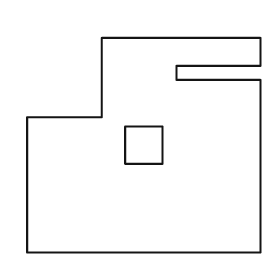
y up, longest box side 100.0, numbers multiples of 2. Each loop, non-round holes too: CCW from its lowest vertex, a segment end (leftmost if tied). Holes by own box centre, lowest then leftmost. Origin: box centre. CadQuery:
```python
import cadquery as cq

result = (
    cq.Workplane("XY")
    .moveTo(-50.0, -46.0)
    .lineTo(50.0, -46.0)
    .lineTo(50.0, 28.0)
    .lineTo(14.0, 28.0)
    .lineTo(14.0, 34.0)
    .lineTo(50.0, 34.0)
    .lineTo(50.0, 46.0)
    .lineTo(-18.0, 46.0)
    .lineTo(-18.0, 12.0)
    .lineTo(-50.0, 12.0)
    .close()
    .moveTo(-8.0, -8.0)
    .lineTo(8.0, -8.0)
    .lineTo(8.0, 8.0)
    .lineTo(-8.0, 8.0)
    .close()
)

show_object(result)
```